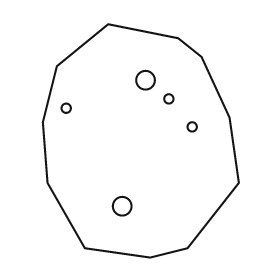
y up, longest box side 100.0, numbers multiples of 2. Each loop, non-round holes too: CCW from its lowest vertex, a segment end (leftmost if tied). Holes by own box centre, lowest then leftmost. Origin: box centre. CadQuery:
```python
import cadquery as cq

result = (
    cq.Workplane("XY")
    .moveTo(4.0, -50.0)
    .lineTo(20.0, -46.0)
    .lineTo(42.0, -18.0)
    .lineTo(38.0, 10.0)
    .lineTo(26.0, 36.0)
    .lineTo(16.0, 44.0)
    .lineTo(-14.0, 50.0)
    .lineTo(-36.0, 32.0)
    .lineTo(-42.0, 8.0)
    .lineTo(-40.0, -18.0)
    .lineTo(-24.0, -46.0)
    .close()
    .moveTo(-8.0, -28.0)
    .circle(4.0)
    .moveTo(22.0, 6.0)
    .circle(2.0)
    .moveTo(-32.0, 14.0)
    .circle(2.0)
    .moveTo(12.0, 18.0)
    .circle(2.0)
    .moveTo(2.0, 26.0)
    .circle(4.0)
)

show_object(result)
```